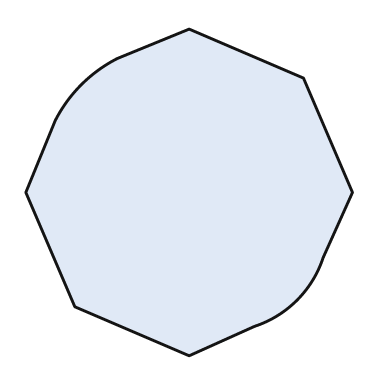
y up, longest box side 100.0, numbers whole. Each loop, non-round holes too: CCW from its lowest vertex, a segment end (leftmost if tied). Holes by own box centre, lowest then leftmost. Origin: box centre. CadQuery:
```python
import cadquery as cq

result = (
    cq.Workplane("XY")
    .moveTo(0.0, -50.0)
    .lineTo(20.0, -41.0)
    .threePointArc((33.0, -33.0), (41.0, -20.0))
    .lineTo(50.0, 0.0)
    .lineTo(35.0, 35.0)
    .lineTo(0.0, 50.0)
    .lineTo(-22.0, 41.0)
    .threePointArc((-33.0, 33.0), (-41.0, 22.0))
    .lineTo(-50.0, 0.0)
    .lineTo(-35.0, -35.0)
    .close()
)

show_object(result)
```